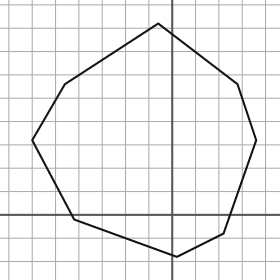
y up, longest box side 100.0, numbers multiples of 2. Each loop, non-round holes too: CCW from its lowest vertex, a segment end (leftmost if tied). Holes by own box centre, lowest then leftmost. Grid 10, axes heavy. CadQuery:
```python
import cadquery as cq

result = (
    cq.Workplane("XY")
    .moveTo(2.0, -18.0)
    .lineTo(22.0, -8.0)
    .lineTo(36.0, 32.0)
    .lineTo(28.0, 56.0)
    .lineTo(-6.0, 82.0)
    .lineTo(-46.0, 56.0)
    .lineTo(-60.0, 32.0)
    .lineTo(-42.0, -2.0)
    .close()
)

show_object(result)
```